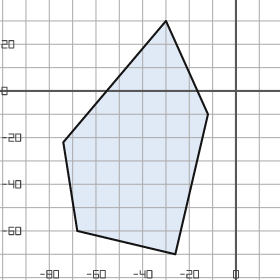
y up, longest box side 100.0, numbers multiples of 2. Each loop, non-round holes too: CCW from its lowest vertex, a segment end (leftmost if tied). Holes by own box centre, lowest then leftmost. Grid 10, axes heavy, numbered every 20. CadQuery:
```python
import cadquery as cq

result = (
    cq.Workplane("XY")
    .moveTo(-26.0, -70.0)
    .lineTo(-12.0, -10.0)
    .lineTo(-30.0, 30.0)
    .lineTo(-74.0, -22.0)
    .lineTo(-68.0, -60.0)
    .close()
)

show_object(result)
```